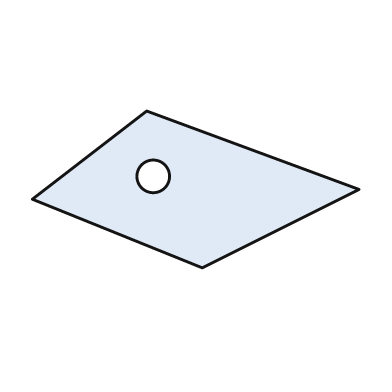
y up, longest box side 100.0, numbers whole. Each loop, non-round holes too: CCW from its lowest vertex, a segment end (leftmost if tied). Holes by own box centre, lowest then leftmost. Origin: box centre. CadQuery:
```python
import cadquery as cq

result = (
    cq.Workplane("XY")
    .moveTo(2.0, -24.0)
    .lineTo(50.0, 0.0)
    .lineTo(-15.0, 24.0)
    .lineTo(-50.0, -3.0)
    .close()
    .moveTo(-13.0, 4.0)
    .circle(5.0)
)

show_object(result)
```